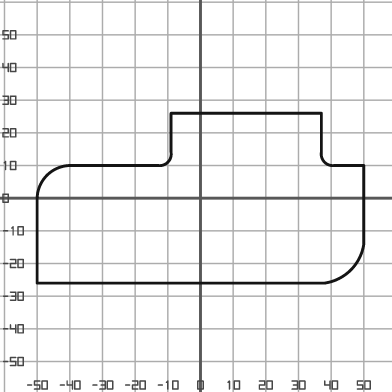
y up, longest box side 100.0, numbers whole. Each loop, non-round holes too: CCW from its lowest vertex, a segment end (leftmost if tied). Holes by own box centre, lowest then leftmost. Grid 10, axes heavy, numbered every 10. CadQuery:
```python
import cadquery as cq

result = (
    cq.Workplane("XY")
    .moveTo(-50.0, -26.0)
    .lineTo(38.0, -26.0)
    .threePointArc((46.0, -22.0), (50.0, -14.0))
    .lineTo(50.0, 10.0)
    .lineTo(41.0, 10.0)
    .threePointArc((38.0, 11.0), (37.0, 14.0))
    .lineTo(37.0, 26.0)
    .lineTo(-9.0, 26.0)
    .lineTo(-9.0, 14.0)
    .threePointArc((-10.0, 11.0), (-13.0, 10.0))
    .lineTo(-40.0, 10.0)
    .threePointArc((-47.0, 7.0), (-50.0, 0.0))
    .close()
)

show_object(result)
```